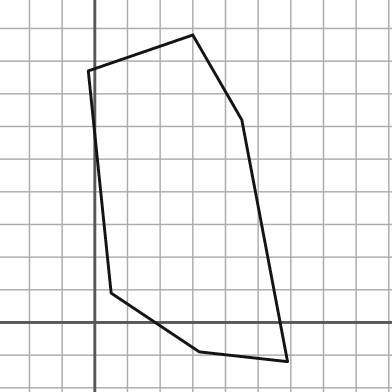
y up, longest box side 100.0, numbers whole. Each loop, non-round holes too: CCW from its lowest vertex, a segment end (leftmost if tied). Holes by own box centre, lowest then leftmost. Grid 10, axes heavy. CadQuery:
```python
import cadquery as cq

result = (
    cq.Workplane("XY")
    .moveTo(59.0, -12.0)
    .lineTo(45.0, 62.0)
    .lineTo(30.0, 88.0)
    .lineTo(-2.0, 77.0)
    .lineTo(5.0, 9.0)
    .lineTo(32.0, -9.0)
    .close()
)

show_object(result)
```